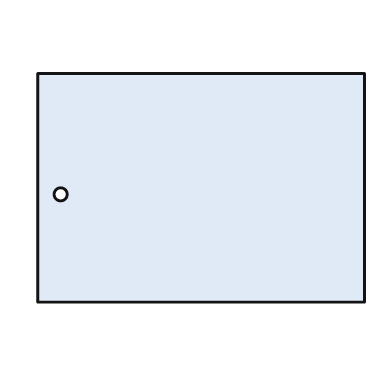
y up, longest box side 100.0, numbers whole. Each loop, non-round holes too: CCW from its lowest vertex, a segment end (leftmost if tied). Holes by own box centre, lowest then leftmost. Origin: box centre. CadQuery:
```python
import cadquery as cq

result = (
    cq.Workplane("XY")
    .moveTo(-50.0, -35.0)
    .lineTo(50.0, -35.0)
    .lineTo(50.0, 35.0)
    .lineTo(-50.0, 35.0)
    .close()
    .moveTo(-43.0, -2.0)
    .circle(2.0)
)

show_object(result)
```